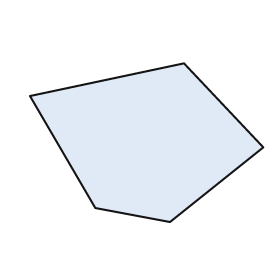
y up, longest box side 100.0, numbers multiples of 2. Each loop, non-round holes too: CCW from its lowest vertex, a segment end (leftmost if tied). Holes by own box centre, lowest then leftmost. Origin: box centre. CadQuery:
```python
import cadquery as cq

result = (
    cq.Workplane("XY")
    .moveTo(10.0, -34.0)
    .lineTo(50.0, -2.0)
    .lineTo(16.0, 34.0)
    .lineTo(-50.0, 20.0)
    .lineTo(-22.0, -28.0)
    .close()
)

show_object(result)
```